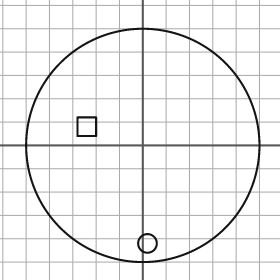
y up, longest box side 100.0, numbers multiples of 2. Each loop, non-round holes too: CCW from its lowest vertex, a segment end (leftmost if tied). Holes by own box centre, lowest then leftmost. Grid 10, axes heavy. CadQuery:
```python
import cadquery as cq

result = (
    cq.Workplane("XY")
    .moveTo(0.0, 0.0)
    .circle(50.0)
    .moveTo(2.0, -42.0)
    .circle(4.0)
    .moveTo(-28.0, 4.0)
    .lineTo(-20.0, 4.0)
    .lineTo(-20.0, 12.0)
    .lineTo(-28.0, 12.0)
    .close()
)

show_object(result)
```